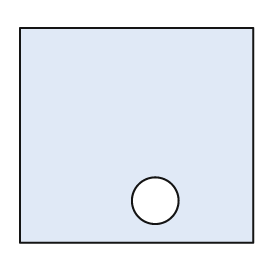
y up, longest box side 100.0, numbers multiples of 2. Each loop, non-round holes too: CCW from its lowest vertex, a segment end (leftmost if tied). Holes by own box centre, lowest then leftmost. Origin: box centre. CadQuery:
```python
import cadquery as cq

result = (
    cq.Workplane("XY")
    .moveTo(-50.0, -46.0)
    .lineTo(50.0, -46.0)
    .lineTo(50.0, 46.0)
    .lineTo(-50.0, 46.0)
    .close()
    .moveTo(8.0, -28.0)
    .circle(10.0)
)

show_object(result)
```